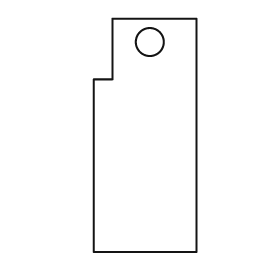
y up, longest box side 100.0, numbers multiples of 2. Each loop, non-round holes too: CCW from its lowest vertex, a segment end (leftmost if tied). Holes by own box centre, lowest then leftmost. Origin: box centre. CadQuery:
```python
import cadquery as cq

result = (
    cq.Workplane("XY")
    .moveTo(-22.0, -50.0)
    .lineTo(22.0, -50.0)
    .lineTo(22.0, 50.0)
    .lineTo(-14.0, 50.0)
    .lineTo(-14.0, 24.0)
    .lineTo(-22.0, 24.0)
    .close()
    .moveTo(2.0, 40.0)
    .circle(6.0)
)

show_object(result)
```